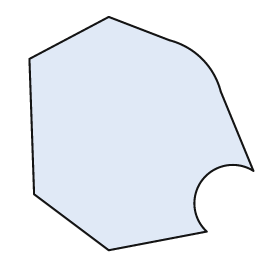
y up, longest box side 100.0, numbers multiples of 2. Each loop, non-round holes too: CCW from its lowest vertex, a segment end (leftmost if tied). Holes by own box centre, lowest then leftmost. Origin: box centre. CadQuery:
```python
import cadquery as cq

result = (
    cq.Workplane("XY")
    .moveTo(-14.0, -50.0)
    .lineTo(28.0, -42.0)
    .threePointArc((26.0, -20.0), (48.0, -16.0))
    .lineTo(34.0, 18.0)
    .threePointArc((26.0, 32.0), (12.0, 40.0))
    .lineTo(-14.0, 50.0)
    .lineTo(-48.0, 32.0)
    .lineTo(-46.0, -26.0)
    .close()
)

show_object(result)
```